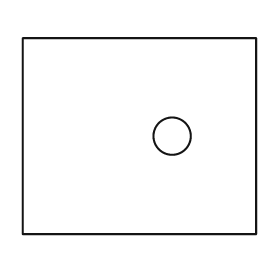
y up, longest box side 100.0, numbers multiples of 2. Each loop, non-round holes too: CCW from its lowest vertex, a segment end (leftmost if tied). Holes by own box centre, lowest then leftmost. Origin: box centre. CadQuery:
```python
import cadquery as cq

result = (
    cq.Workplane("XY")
    .moveTo(-50.0, -42.0)
    .lineTo(50.0, -42.0)
    .lineTo(50.0, 42.0)
    .lineTo(-50.0, 42.0)
    .close()
    .moveTo(14.0, 0.0)
    .circle(8.0)
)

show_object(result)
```